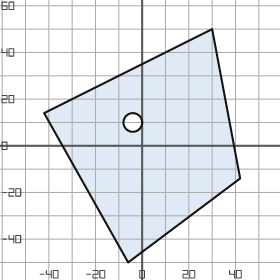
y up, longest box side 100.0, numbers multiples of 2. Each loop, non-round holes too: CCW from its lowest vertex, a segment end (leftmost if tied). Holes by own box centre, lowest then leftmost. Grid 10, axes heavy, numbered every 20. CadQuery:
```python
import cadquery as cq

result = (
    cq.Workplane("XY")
    .moveTo(-6.0, -50.0)
    .lineTo(42.0, -14.0)
    .lineTo(30.0, 50.0)
    .lineTo(-42.0, 14.0)
    .close()
    .moveTo(-4.0, 10.0)
    .circle(4.0)
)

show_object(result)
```